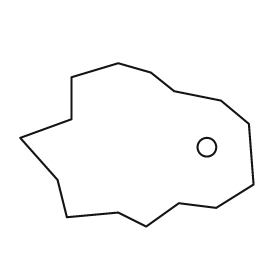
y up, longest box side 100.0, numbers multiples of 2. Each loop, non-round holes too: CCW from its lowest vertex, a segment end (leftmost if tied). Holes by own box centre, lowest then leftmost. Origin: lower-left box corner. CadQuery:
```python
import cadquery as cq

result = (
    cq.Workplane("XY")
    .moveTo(54.0, 0.0)
    .lineTo(68.0, 10.0)
    .lineTo(84.0, 8.0)
    .lineTo(100.0, 18.0)
    .lineTo(98.0, 44.0)
    .lineTo(86.0, 54.0)
    .lineTo(66.0, 58.0)
    .lineTo(56.0, 66.0)
    .lineTo(42.0, 70.0)
    .lineTo(22.0, 64.0)
    .lineTo(22.0, 46.0)
    .lineTo(0.0, 38.0)
    .lineTo(16.0, 20.0)
    .lineTo(20.0, 4.0)
    .lineTo(42.0, 6.0)
    .close()
    .moveTo(80.0, 34.0)
    .circle(4.0)
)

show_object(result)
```